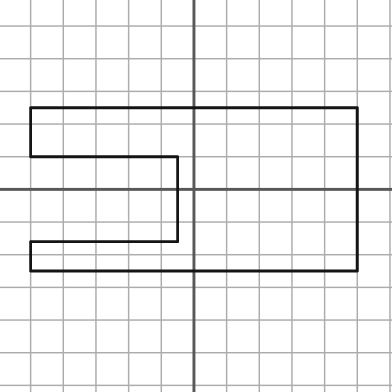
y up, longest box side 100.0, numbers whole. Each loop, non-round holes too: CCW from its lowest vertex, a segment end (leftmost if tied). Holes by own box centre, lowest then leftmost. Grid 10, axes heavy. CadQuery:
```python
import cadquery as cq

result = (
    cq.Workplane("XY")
    .moveTo(-50.0, -25.0)
    .lineTo(50.0, -25.0)
    .lineTo(50.0, 25.0)
    .lineTo(-50.0, 25.0)
    .lineTo(-50.0, 10.0)
    .lineTo(-5.0, 10.0)
    .lineTo(-5.0, -16.0)
    .lineTo(-50.0, -16.0)
    .close()
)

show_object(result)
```